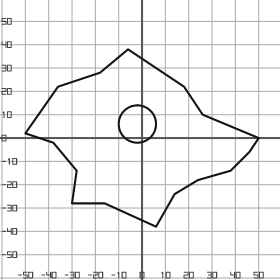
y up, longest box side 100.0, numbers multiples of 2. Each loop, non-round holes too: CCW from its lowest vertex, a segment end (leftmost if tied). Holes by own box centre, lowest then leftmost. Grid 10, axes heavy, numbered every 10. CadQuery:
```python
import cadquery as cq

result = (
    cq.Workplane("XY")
    .moveTo(6.0, -38.0)
    .lineTo(14.0, -24.0)
    .lineTo(24.0, -18.0)
    .lineTo(38.0, -14.0)
    .lineTo(46.0, -6.0)
    .lineTo(50.0, 0.0)
    .lineTo(26.0, 10.0)
    .lineTo(18.0, 22.0)
    .lineTo(-6.0, 38.0)
    .lineTo(-18.0, 28.0)
    .lineTo(-36.0, 22.0)
    .lineTo(-50.0, 2.0)
    .lineTo(-38.0, -2.0)
    .lineTo(-28.0, -14.0)
    .lineTo(-30.0, -28.0)
    .lineTo(-16.0, -28.0)
    .close()
    .moveTo(-2.0, 6.0)
    .circle(8.0)
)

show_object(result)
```